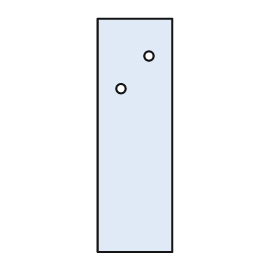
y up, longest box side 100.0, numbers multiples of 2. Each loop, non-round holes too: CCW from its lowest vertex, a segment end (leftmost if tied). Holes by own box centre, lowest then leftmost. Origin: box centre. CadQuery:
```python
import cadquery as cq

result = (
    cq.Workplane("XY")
    .moveTo(-16.0, -50.0)
    .lineTo(16.0, -50.0)
    .lineTo(16.0, 50.0)
    .lineTo(-16.0, 50.0)
    .close()
    .moveTo(-6.0, 20.0)
    .circle(2.0)
    .moveTo(6.0, 34.0)
    .circle(2.0)
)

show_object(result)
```